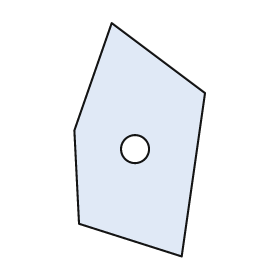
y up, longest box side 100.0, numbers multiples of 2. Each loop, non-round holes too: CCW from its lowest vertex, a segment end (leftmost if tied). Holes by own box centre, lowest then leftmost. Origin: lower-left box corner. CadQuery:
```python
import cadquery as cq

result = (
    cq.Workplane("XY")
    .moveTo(46.0, 0.0)
    .lineTo(56.0, 70.0)
    .lineTo(16.0, 100.0)
    .lineTo(0.0, 54.0)
    .lineTo(2.0, 14.0)
    .close()
    .moveTo(26.0, 46.0)
    .circle(6.0)
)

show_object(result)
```